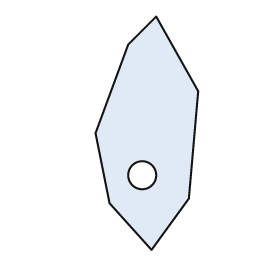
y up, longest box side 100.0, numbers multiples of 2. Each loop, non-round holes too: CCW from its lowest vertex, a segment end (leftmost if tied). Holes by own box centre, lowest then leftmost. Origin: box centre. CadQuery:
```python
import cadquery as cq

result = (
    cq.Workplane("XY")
    .moveTo(2.0, -50.0)
    .lineTo(18.0, -28.0)
    .lineTo(22.0, 18.0)
    .lineTo(4.0, 50.0)
    .lineTo(-8.0, 38.0)
    .lineTo(-22.0, 0.0)
    .lineTo(-16.0, -30.0)
    .close()
    .moveTo(-2.0, -18.0)
    .circle(6.0)
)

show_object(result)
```